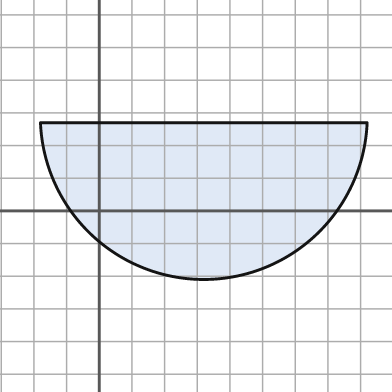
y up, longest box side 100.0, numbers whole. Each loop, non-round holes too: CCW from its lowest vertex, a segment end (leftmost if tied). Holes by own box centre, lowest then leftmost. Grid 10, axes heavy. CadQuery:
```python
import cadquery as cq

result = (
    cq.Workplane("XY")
    .moveTo(-18.0, 27.0)
    .threePointArc((32.0, -21.0), (82.0, 27.0))
    .close()
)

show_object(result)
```